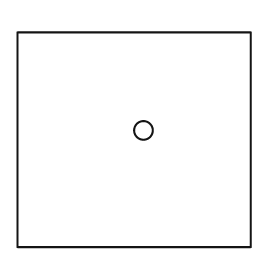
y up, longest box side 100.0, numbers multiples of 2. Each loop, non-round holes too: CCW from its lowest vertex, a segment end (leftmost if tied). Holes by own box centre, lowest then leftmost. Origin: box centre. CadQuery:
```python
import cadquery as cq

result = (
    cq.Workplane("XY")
    .moveTo(-50.0, -46.0)
    .lineTo(50.0, -46.0)
    .lineTo(50.0, 46.0)
    .lineTo(-50.0, 46.0)
    .close()
    .moveTo(4.0, 4.0)
    .circle(4.0)
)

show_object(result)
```